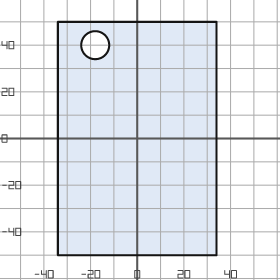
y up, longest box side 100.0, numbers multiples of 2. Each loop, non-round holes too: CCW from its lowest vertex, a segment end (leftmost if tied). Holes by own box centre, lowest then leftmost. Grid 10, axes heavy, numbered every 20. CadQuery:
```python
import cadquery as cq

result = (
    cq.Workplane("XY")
    .moveTo(-34.0, -50.0)
    .lineTo(34.0, -50.0)
    .lineTo(34.0, 50.0)
    .lineTo(-34.0, 50.0)
    .close()
    .moveTo(-18.0, 40.0)
    .circle(6.0)
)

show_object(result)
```